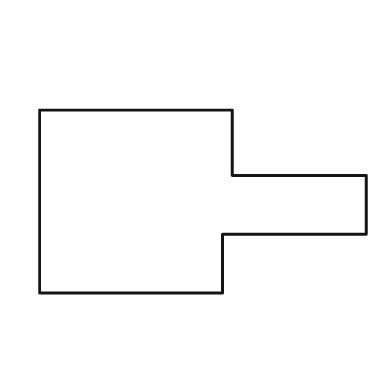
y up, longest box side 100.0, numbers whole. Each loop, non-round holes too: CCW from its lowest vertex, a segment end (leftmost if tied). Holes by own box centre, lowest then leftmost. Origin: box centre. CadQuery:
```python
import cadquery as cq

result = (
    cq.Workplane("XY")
    .moveTo(-50.0, -28.0)
    .lineTo(6.0, -28.0)
    .lineTo(6.0, -10.0)
    .lineTo(50.0, -10.0)
    .lineTo(50.0, 8.0)
    .lineTo(9.0, 8.0)
    .lineTo(9.0, 28.0)
    .lineTo(-50.0, 28.0)
    .close()
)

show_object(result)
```